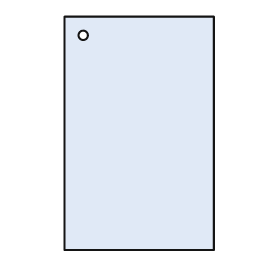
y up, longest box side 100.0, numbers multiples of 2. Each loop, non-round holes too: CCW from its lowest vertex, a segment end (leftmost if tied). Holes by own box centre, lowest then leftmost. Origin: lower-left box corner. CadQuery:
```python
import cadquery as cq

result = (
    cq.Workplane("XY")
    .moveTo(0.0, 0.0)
    .lineTo(64.0, 0.0)
    .lineTo(64.0, 100.0)
    .lineTo(0.0, 100.0)
    .close()
    .moveTo(8.0, 92.0)
    .circle(2.0)
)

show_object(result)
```